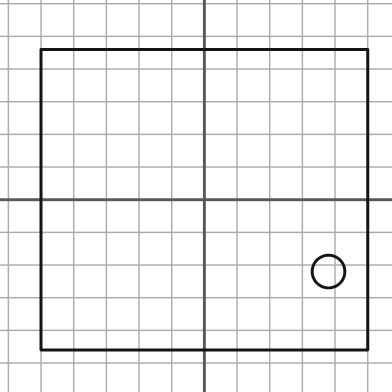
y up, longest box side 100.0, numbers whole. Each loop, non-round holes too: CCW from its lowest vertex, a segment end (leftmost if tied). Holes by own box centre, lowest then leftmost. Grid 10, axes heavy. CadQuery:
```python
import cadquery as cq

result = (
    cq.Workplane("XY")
    .moveTo(-50.0, -46.0)
    .lineTo(50.0, -46.0)
    .lineTo(50.0, 46.0)
    .lineTo(-50.0, 46.0)
    .close()
    .moveTo(38.0, -22.0)
    .circle(5.0)
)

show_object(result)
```